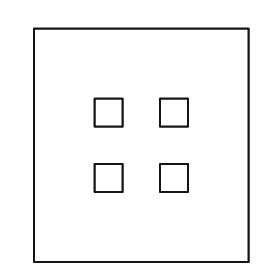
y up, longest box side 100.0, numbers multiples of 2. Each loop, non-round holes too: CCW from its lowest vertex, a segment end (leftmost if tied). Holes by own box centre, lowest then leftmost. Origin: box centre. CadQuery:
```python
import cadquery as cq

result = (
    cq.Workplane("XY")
    .moveTo(-46.0, -50.0)
    .lineTo(46.0, -50.0)
    .lineTo(46.0, 50.0)
    .lineTo(-46.0, 50.0)
    .close()
    .moveTo(-20.0, -20.0)
    .lineTo(-8.0, -20.0)
    .lineTo(-8.0, -8.0)
    .lineTo(-20.0, -8.0)
    .close()
    .moveTo(8.0, -20.0)
    .lineTo(20.0, -20.0)
    .lineTo(20.0, -8.0)
    .lineTo(8.0, -8.0)
    .close()
    .moveTo(-20.0, 8.0)
    .lineTo(-8.0, 8.0)
    .lineTo(-8.0, 20.0)
    .lineTo(-20.0, 20.0)
    .close()
    .moveTo(8.0, 8.0)
    .lineTo(20.0, 8.0)
    .lineTo(20.0, 20.0)
    .lineTo(8.0, 20.0)
    .close()
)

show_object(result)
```